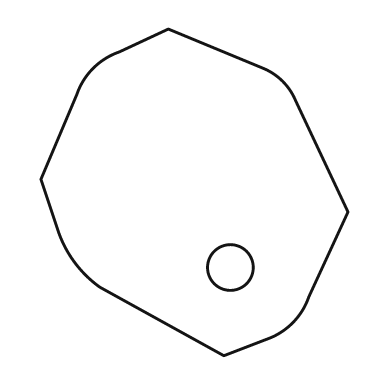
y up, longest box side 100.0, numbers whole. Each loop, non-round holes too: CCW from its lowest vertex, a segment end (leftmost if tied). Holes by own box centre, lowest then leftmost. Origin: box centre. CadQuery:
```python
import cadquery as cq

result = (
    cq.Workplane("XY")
    .moveTo(9.0, -50.0)
    .lineTo(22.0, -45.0)
    .threePointArc((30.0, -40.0), (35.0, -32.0))
    .lineTo(47.0, -6.0)
    .lineTo(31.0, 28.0)
    .threePointArc((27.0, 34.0), (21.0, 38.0))
    .lineTo(-8.0, 50.0)
    .lineTo(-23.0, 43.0)
    .threePointArc((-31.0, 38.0), (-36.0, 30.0))
    .lineTo(-47.0, 4.0)
    .lineTo(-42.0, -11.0)
    .threePointArc((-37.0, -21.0), (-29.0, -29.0))
    .close()
    .moveTo(11.0, -23.0)
    .circle(7.0)
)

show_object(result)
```